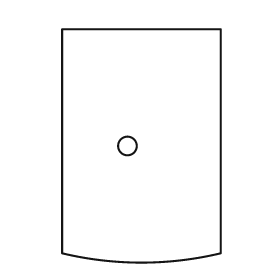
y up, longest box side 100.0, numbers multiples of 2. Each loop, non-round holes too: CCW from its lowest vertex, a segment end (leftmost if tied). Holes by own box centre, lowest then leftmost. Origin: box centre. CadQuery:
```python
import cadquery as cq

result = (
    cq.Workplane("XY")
    .moveTo(-34.0, -46.0)
    .threePointArc((0.0, -50.0), (34.0, -46.0))
    .lineTo(34.0, 50.0)
    .lineTo(-34.0, 50.0)
    .close()
    .moveTo(-6.0, 0.0)
    .circle(4.0)
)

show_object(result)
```